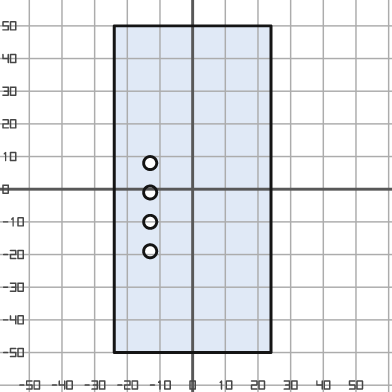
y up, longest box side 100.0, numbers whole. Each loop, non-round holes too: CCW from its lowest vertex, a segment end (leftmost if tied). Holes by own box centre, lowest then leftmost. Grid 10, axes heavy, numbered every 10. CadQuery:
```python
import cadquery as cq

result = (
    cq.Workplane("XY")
    .moveTo(-24.0, -50.0)
    .lineTo(24.0, -50.0)
    .lineTo(24.0, 50.0)
    .lineTo(-24.0, 50.0)
    .close()
    .moveTo(-13.0, -19.0)
    .circle(2.0)
    .moveTo(-13.0, -10.0)
    .circle(2.0)
    .moveTo(-13.0, -1.0)
    .circle(2.0)
    .moveTo(-13.0, 8.0)
    .circle(2.0)
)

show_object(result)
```